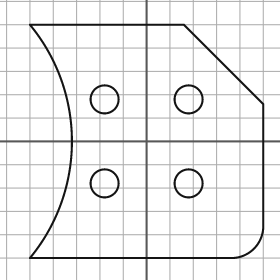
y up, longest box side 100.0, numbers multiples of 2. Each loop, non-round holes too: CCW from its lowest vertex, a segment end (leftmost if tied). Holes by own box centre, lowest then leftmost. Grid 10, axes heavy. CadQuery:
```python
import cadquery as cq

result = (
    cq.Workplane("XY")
    .moveTo(-50.0, -50.0)
    .lineTo(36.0, -50.0)
    .threePointArc((46.0, -46.0), (50.0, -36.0))
    .lineTo(50.0, 16.0)
    .lineTo(16.0, 50.0)
    .lineTo(-50.0, 50.0)
    .threePointArc((-32.0, 0.0), (-50.0, -50.0))
    .close()
    .moveTo(-18.0, -18.0)
    .circle(6.0)
    .moveTo(18.0, -18.0)
    .circle(6.0)
    .moveTo(-18.0, 18.0)
    .circle(6.0)
    .moveTo(18.0, 18.0)
    .circle(6.0)
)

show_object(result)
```